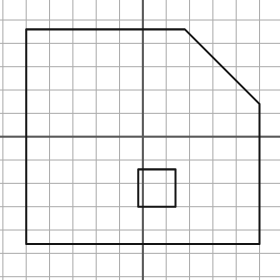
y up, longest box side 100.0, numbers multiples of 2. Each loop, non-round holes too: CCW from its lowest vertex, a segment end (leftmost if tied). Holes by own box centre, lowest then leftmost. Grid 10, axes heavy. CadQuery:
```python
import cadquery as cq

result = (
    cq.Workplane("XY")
    .moveTo(-50.0, -46.0)
    .lineTo(50.0, -46.0)
    .lineTo(50.0, 14.0)
    .lineTo(18.0, 46.0)
    .lineTo(-50.0, 46.0)
    .close()
    .moveTo(-2.0, -30.0)
    .lineTo(14.0, -30.0)
    .lineTo(14.0, -14.0)
    .lineTo(-2.0, -14.0)
    .close()
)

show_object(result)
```